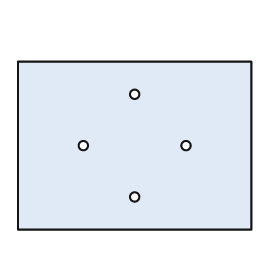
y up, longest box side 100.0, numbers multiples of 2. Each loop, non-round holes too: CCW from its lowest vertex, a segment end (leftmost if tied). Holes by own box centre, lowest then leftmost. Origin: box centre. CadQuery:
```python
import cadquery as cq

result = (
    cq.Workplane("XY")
    .moveTo(-50.0, -36.0)
    .lineTo(50.0, -36.0)
    .lineTo(50.0, 36.0)
    .lineTo(-50.0, 36.0)
    .close()
    .moveTo(0.0, -22.0)
    .circle(2.0)
    .moveTo(-22.0, 0.0)
    .circle(2.0)
    .moveTo(22.0, 0.0)
    .circle(2.0)
    .moveTo(0.0, 22.0)
    .circle(2.0)
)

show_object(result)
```